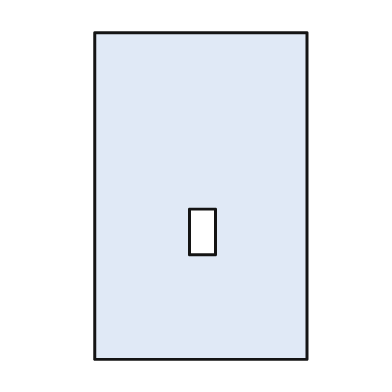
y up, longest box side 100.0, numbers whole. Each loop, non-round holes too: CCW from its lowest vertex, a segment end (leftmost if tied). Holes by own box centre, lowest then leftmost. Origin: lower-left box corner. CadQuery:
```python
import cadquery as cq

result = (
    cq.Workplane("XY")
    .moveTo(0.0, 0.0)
    .lineTo(65.0, 0.0)
    .lineTo(65.0, 100.0)
    .lineTo(0.0, 100.0)
    .close()
    .moveTo(29.0, 32.0)
    .lineTo(37.0, 32.0)
    .lineTo(37.0, 46.0)
    .lineTo(29.0, 46.0)
    .close()
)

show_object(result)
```